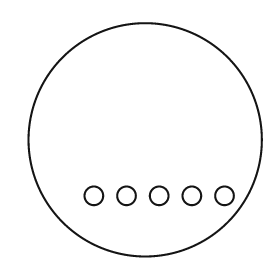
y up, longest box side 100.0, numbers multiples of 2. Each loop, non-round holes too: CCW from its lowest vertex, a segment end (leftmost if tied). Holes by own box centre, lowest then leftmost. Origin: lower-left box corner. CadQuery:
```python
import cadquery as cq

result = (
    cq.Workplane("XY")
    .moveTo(50.0, 50.0)
    .circle(50.0)
    .moveTo(28.0, 26.0)
    .circle(4.0)
    .moveTo(42.0, 26.0)
    .circle(4.0)
    .moveTo(56.0, 26.0)
    .circle(4.0)
    .moveTo(70.0, 26.0)
    .circle(4.0)
    .moveTo(84.0, 26.0)
    .circle(4.0)
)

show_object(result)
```